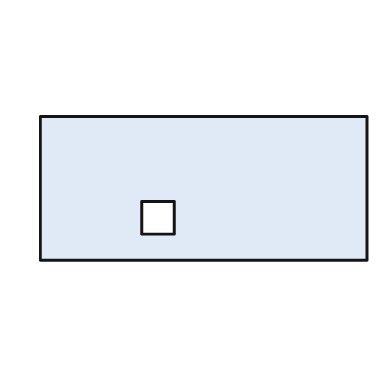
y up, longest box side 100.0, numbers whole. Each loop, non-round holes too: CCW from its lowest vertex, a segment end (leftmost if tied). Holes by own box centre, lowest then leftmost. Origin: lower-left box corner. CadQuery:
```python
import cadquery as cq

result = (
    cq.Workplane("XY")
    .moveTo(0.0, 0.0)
    .lineTo(100.0, 0.0)
    .lineTo(100.0, 44.0)
    .lineTo(0.0, 44.0)
    .close()
    .moveTo(31.0, 8.0)
    .lineTo(41.0, 8.0)
    .lineTo(41.0, 18.0)
    .lineTo(31.0, 18.0)
    .close()
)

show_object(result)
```